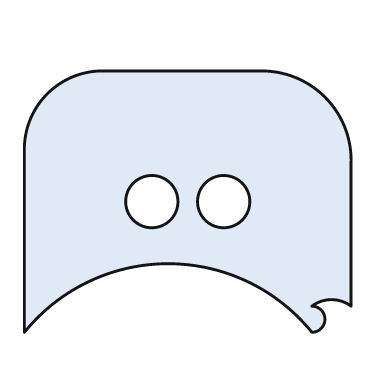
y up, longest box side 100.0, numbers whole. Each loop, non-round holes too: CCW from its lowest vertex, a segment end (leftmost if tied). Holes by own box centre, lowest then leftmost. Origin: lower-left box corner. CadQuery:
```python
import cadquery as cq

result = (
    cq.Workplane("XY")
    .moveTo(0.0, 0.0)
    .threePointArc((44.0, 21.0), (88.0, 0.0))
    .threePointArc((92.0, 4.0), (88.0, 8.0))
    .threePointArc((94.0, 10.0), (100.0, 8.0))
    .lineTo(100.0, 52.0)
    .threePointArc((92.0, 72.0), (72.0, 80.0))
    .lineTo(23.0, 80.0)
    .threePointArc((7.0, 73.0), (0.0, 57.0))
    .close()
    .moveTo(39.0, 40.0)
    .circle(8.0)
    .moveTo(61.0, 40.0)
    .circle(8.0)
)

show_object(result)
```